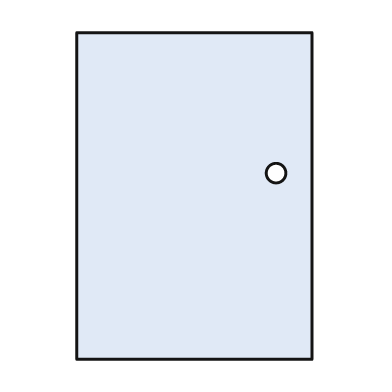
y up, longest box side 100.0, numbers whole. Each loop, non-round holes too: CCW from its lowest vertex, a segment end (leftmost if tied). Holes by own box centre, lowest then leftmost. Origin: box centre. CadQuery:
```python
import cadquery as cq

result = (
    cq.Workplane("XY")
    .moveTo(-36.0, -50.0)
    .lineTo(36.0, -50.0)
    .lineTo(36.0, 50.0)
    .lineTo(-36.0, 50.0)
    .close()
    .moveTo(25.0, 7.0)
    .circle(3.0)
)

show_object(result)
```